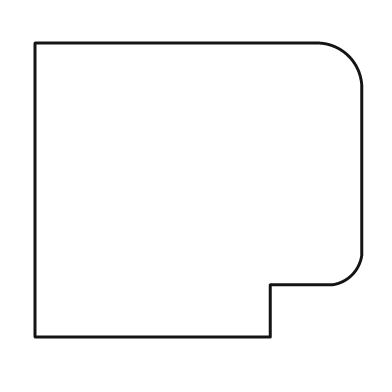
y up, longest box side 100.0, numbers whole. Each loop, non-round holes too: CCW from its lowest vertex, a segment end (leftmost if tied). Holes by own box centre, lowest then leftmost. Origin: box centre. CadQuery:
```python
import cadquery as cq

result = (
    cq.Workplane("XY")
    .moveTo(-50.0, -45.0)
    .lineTo(22.0, -45.0)
    .lineTo(22.0, -29.0)
    .lineTo(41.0, -29.0)
    .threePointArc((47.0, -26.0), (50.0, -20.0))
    .lineTo(50.0, 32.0)
    .threePointArc((46.0, 41.0), (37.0, 45.0))
    .lineTo(-50.0, 45.0)
    .close()
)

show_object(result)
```